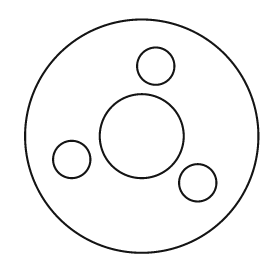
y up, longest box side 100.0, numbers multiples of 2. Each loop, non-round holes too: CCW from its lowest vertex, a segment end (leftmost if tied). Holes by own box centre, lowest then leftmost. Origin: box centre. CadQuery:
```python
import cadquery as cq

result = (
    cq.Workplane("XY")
    .moveTo(0.0, 0.0)
    .circle(50.0)
    .moveTo(24.0, -20.0)
    .circle(8.0)
    .moveTo(-30.0, -10.0)
    .circle(8.0)
    .moveTo(0.0, 0.0)
    .circle(18.0)
    .moveTo(6.0, 30.0)
    .circle(8.0)
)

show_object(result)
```